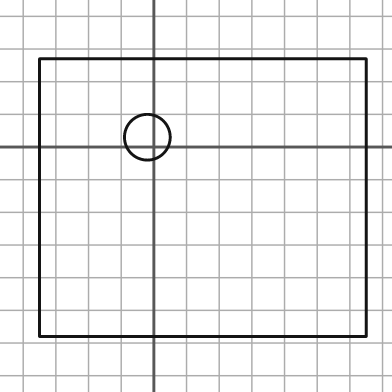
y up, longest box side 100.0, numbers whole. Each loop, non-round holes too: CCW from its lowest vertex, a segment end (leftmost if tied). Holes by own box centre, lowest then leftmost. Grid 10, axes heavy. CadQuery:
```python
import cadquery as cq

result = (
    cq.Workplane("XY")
    .moveTo(-35.0, -58.0)
    .lineTo(65.0, -58.0)
    .lineTo(65.0, 27.0)
    .lineTo(-35.0, 27.0)
    .close()
    .moveTo(-2.0, 3.0)
    .circle(7.0)
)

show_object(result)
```